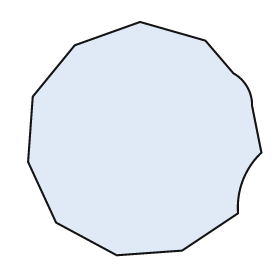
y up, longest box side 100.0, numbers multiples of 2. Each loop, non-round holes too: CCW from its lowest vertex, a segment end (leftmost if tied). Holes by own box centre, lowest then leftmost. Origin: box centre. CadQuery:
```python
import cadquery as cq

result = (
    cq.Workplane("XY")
    .moveTo(-12.0, -50.0)
    .lineTo(16.0, -48.0)
    .lineTo(40.0, -32.0)
    .threePointArc((42.0, -18.0), (50.0, -6.0))
    .lineTo(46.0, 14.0)
    .threePointArc((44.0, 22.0), (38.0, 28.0))
    .lineTo(26.0, 42.0)
    .lineTo(-2.0, 50.0)
    .lineTo(-30.0, 40.0)
    .lineTo(-48.0, 18.0)
    .lineTo(-50.0, -10.0)
    .lineTo(-38.0, -36.0)
    .close()
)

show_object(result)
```